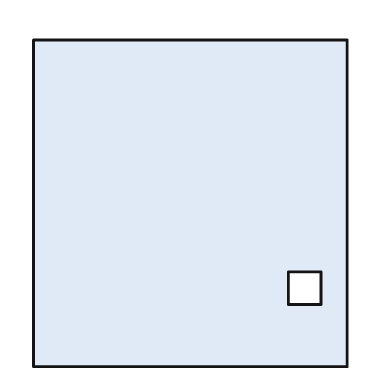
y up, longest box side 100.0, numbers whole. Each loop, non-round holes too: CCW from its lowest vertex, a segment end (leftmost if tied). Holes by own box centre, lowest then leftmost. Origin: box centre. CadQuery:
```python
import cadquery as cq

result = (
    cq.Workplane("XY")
    .moveTo(-48.0, -50.0)
    .lineTo(48.0, -50.0)
    .lineTo(48.0, 50.0)
    .lineTo(-48.0, 50.0)
    .close()
    .moveTo(30.0, -31.0)
    .lineTo(40.0, -31.0)
    .lineTo(40.0, -21.0)
    .lineTo(30.0, -21.0)
    .close()
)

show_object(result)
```